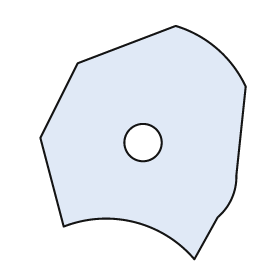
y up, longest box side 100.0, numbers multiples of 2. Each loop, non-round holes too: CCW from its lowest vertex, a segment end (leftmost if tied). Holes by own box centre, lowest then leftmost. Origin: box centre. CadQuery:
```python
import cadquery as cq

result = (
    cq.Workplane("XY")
    .moveTo(22.0, -50.0)
    .lineTo(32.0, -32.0)
    .threePointArc((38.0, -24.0), (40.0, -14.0))
    .lineTo(44.0, 24.0)
    .threePointArc((32.0, 40.0), (14.0, 50.0))
    .lineTo(-28.0, 34.0)
    .lineTo(-44.0, 2.0)
    .lineTo(-34.0, -36.0)
    .threePointArc((-4.0, -34.0), (22.0, -50.0))
    .close()
    .moveTo(0.0, 0.0)
    .circle(8.0)
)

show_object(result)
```